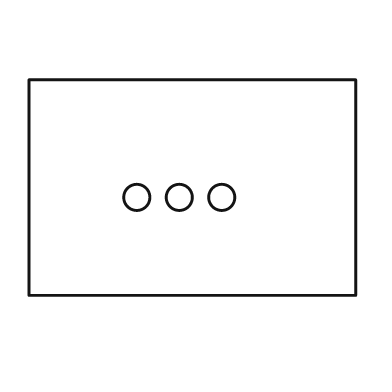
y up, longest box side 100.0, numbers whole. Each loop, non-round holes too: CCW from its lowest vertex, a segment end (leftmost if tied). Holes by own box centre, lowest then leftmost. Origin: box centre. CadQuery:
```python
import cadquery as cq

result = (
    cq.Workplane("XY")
    .moveTo(-50.0, -33.0)
    .lineTo(50.0, -33.0)
    .lineTo(50.0, 33.0)
    .lineTo(-50.0, 33.0)
    .close()
    .moveTo(-17.0, -3.0)
    .circle(4.0)
    .moveTo(-4.0, -3.0)
    .circle(4.0)
    .moveTo(9.0, -3.0)
    .circle(4.0)
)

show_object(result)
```